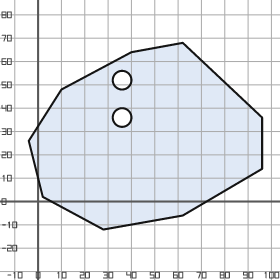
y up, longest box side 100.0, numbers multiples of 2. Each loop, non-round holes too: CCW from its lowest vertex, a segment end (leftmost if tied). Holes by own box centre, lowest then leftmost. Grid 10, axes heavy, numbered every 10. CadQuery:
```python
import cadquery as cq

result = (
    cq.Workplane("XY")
    .moveTo(28.0, -12.0)
    .lineTo(62.0, -6.0)
    .lineTo(96.0, 14.0)
    .lineTo(96.0, 36.0)
    .lineTo(62.0, 68.0)
    .lineTo(40.0, 64.0)
    .lineTo(10.0, 48.0)
    .lineTo(-4.0, 26.0)
    .lineTo(2.0, 2.0)
    .close()
    .moveTo(36.0, 36.0)
    .circle(4.0)
    .moveTo(36.0, 52.0)
    .circle(4.0)
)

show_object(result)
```